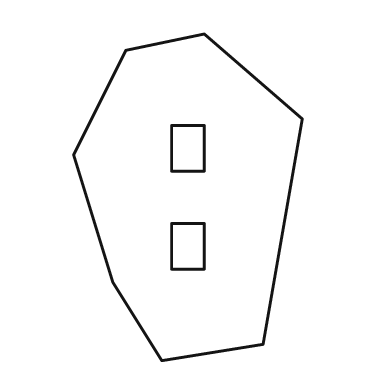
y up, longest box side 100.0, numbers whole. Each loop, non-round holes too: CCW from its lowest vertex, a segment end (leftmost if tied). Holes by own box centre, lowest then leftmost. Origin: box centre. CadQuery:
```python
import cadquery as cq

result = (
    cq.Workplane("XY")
    .moveTo(-8.0, -50.0)
    .lineTo(23.0, -45.0)
    .lineTo(35.0, 24.0)
    .lineTo(5.0, 50.0)
    .lineTo(-19.0, 45.0)
    .lineTo(-35.0, 13.0)
    .lineTo(-23.0, -26.0)
    .close()
    .moveTo(-5.0, -22.0)
    .lineTo(5.0, -22.0)
    .lineTo(5.0, -8.0)
    .lineTo(-5.0, -8.0)
    .close()
    .moveTo(-5.0, 8.0)
    .lineTo(5.0, 8.0)
    .lineTo(5.0, 22.0)
    .lineTo(-5.0, 22.0)
    .close()
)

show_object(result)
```